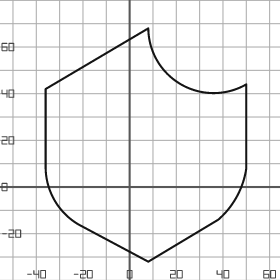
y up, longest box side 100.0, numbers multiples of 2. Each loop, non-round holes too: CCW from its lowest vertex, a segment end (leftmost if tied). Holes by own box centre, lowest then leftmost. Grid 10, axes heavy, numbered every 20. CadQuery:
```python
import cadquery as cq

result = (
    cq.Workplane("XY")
    .moveTo(8.0, -32.0)
    .lineTo(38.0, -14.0)
    .threePointArc((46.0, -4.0), (50.0, 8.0))
    .lineTo(50.0, 44.0)
    .threePointArc((22.0, 44.0), (8.0, 68.0))
    .lineTo(-36.0, 42.0)
    .lineTo(-36.0, 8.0)
    .threePointArc((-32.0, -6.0), (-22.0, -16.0))
    .close()
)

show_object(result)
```